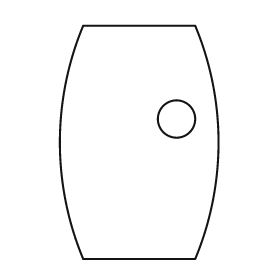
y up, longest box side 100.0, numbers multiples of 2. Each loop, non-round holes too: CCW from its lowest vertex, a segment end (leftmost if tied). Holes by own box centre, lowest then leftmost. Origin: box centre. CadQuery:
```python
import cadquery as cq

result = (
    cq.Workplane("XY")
    .moveTo(-24.0, -50.0)
    .lineTo(24.0, -50.0)
    .threePointArc((34.0, 0.0), (24.0, 50.0))
    .lineTo(-24.0, 50.0)
    .threePointArc((-34.0, 0.0), (-24.0, -50.0))
    .close()
    .moveTo(16.0, 10.0)
    .circle(8.0)
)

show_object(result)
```